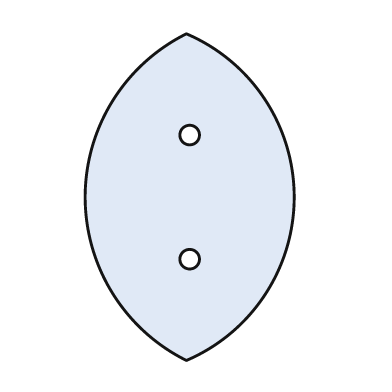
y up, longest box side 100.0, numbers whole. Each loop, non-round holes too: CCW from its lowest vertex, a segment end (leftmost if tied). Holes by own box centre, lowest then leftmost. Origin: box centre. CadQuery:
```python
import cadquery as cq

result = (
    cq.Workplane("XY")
    .moveTo(-1.0, -50.0)
    .threePointArc((32.0, 0.0), (-1.0, 50.0))
    .threePointArc((-32.0, 0.0), (-1.0, -50.0))
    .close()
    .moveTo(0.0, -19.0)
    .circle(3.0)
    .moveTo(0.0, 19.0)
    .circle(3.0)
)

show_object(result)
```